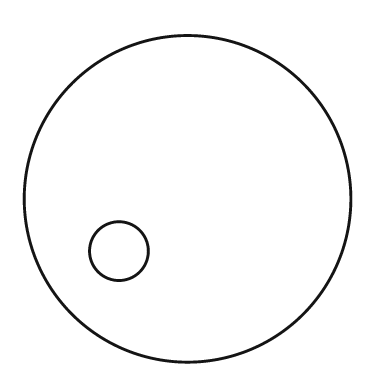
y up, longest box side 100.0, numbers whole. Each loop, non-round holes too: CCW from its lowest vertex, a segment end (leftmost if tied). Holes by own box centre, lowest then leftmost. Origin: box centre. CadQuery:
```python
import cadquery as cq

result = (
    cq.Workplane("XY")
    .moveTo(0.0, 0.0)
    .circle(50.0)
    .moveTo(-21.0, -16.0)
    .circle(9.0)
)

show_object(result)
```